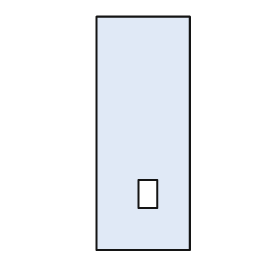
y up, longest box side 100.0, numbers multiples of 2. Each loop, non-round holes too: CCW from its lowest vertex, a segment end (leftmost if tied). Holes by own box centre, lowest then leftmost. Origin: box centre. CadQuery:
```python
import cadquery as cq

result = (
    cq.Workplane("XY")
    .moveTo(-20.0, -50.0)
    .lineTo(20.0, -50.0)
    .lineTo(20.0, 50.0)
    .lineTo(-20.0, 50.0)
    .close()
    .moveTo(-2.0, -32.0)
    .lineTo(6.0, -32.0)
    .lineTo(6.0, -20.0)
    .lineTo(-2.0, -20.0)
    .close()
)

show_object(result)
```